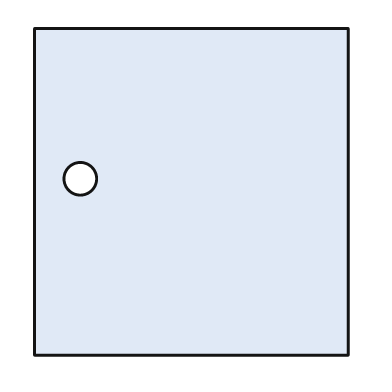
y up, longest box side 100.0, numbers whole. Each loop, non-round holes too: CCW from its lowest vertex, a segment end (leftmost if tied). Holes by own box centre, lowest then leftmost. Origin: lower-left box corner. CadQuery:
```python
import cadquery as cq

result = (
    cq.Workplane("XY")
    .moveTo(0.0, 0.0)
    .lineTo(96.0, 0.0)
    .lineTo(96.0, 100.0)
    .lineTo(0.0, 100.0)
    .close()
    .moveTo(14.0, 54.0)
    .circle(5.0)
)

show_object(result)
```